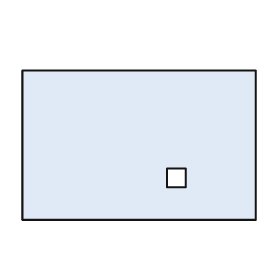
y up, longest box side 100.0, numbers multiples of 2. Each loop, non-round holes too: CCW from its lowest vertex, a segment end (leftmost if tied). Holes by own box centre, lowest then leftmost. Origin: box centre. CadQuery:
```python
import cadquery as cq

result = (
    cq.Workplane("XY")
    .moveTo(-50.0, -32.0)
    .lineTo(50.0, -32.0)
    .lineTo(50.0, 32.0)
    .lineTo(-50.0, 32.0)
    .close()
    .moveTo(12.0, -18.0)
    .lineTo(20.0, -18.0)
    .lineTo(20.0, -10.0)
    .lineTo(12.0, -10.0)
    .close()
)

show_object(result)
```